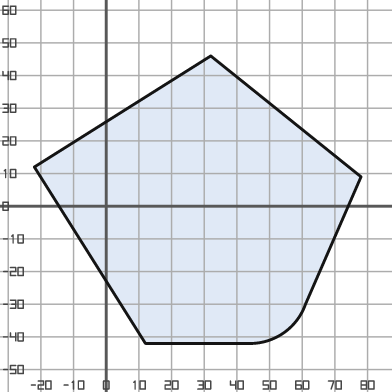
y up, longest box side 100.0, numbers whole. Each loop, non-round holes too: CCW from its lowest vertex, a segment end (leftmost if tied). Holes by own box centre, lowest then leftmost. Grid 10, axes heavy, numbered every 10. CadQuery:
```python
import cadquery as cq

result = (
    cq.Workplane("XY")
    .moveTo(12.0, -42.0)
    .lineTo(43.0, -42.0)
    .threePointArc((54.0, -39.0), (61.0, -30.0))
    .lineTo(78.0, 9.0)
    .lineTo(32.0, 46.0)
    .lineTo(-22.0, 12.0)
    .close()
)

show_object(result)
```